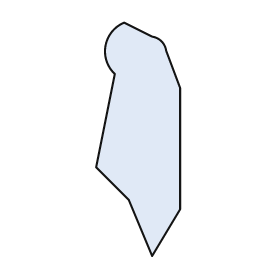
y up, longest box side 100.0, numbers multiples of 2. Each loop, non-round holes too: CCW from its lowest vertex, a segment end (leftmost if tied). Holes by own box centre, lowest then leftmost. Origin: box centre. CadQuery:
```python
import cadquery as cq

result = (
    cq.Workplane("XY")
    .moveTo(6.0, -50.0)
    .lineTo(18.0, -30.0)
    .lineTo(18.0, 22.0)
    .lineTo(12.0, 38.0)
    .threePointArc((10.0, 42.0), (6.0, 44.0))
    .lineTo(-6.0, 50.0)
    .threePointArc((-14.0, 40.0), (-10.0, 28.0))
    .lineTo(-18.0, -12.0)
    .lineTo(-4.0, -26.0)
    .close()
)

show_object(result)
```